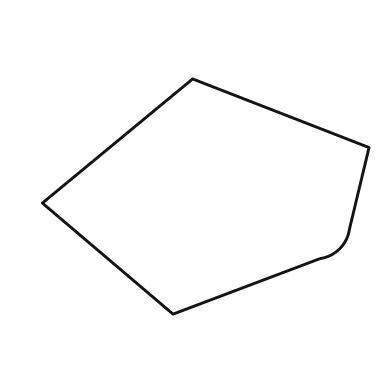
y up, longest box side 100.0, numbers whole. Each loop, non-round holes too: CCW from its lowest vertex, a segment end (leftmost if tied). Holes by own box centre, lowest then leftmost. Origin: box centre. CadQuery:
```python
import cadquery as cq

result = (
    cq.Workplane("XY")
    .moveTo(-10.0, -36.0)
    .lineTo(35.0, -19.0)
    .threePointArc((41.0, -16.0), (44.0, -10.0))
    .lineTo(50.0, 15.0)
    .lineTo(-4.0, 36.0)
    .lineTo(-50.0, -2.0)
    .close()
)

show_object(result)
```